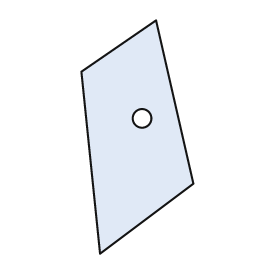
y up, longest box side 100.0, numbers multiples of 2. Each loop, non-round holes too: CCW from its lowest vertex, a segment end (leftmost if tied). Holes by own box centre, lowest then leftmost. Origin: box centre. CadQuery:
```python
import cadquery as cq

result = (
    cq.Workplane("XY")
    .moveTo(-16.0, -50.0)
    .lineTo(24.0, -20.0)
    .lineTo(8.0, 50.0)
    .lineTo(-24.0, 28.0)
    .close()
    .moveTo(2.0, 8.0)
    .circle(4.0)
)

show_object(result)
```